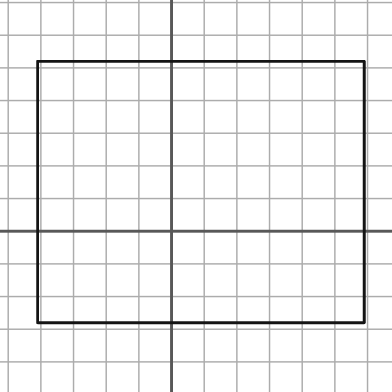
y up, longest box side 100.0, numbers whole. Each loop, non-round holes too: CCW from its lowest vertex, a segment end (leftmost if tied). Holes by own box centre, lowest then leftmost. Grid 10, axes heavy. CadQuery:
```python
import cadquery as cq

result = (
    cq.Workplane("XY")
    .moveTo(-41.0, -28.0)
    .lineTo(59.0, -28.0)
    .lineTo(59.0, 52.0)
    .lineTo(-41.0, 52.0)
    .close()
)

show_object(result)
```